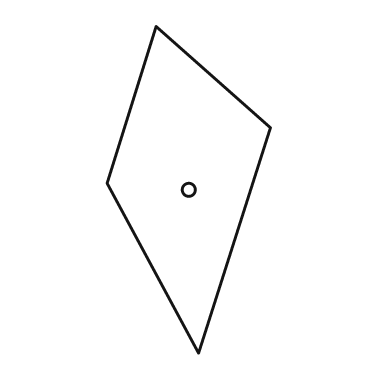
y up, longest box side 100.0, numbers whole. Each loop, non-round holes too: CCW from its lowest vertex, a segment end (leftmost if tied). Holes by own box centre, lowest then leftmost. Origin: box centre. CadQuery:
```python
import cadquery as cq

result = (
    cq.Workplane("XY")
    .moveTo(3.0, -50.0)
    .lineTo(25.0, 19.0)
    .lineTo(-10.0, 50.0)
    .lineTo(-25.0, 2.0)
    .close()
    .moveTo(0.0, 0.0)
    .circle(2.0)
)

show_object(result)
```